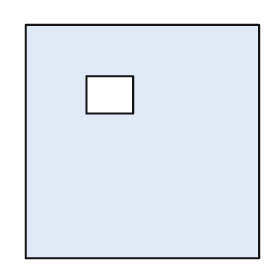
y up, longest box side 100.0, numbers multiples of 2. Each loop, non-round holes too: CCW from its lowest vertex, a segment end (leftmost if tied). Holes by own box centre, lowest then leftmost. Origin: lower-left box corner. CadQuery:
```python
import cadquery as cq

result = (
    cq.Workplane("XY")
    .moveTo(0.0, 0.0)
    .lineTo(100.0, 0.0)
    .lineTo(100.0, 100.0)
    .lineTo(0.0, 100.0)
    .close()
    .moveTo(26.0, 62.0)
    .lineTo(46.0, 62.0)
    .lineTo(46.0, 78.0)
    .lineTo(26.0, 78.0)
    .close()
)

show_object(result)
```